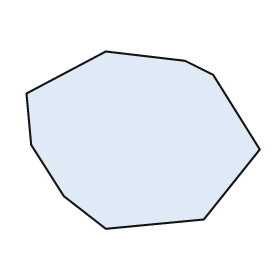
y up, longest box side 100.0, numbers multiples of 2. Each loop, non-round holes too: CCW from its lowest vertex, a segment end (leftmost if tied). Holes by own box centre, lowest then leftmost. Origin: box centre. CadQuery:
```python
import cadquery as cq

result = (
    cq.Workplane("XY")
    .moveTo(-16.0, -38.0)
    .lineTo(26.0, -34.0)
    .lineTo(50.0, -4.0)
    .lineTo(30.0, 28.0)
    .lineTo(18.0, 34.0)
    .lineTo(-16.0, 38.0)
    .lineTo(-50.0, 20.0)
    .lineTo(-48.0, -2.0)
    .lineTo(-34.0, -24.0)
    .close()
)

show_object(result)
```